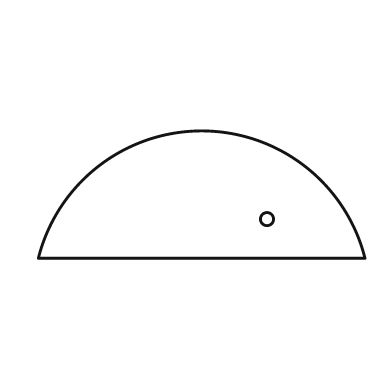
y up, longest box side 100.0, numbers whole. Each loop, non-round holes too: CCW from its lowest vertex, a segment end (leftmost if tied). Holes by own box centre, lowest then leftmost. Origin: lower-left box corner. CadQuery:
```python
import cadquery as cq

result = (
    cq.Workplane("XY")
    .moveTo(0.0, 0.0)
    .lineTo(100.0, 0.0)
    .threePointArc((50.0, 39.0), (0.0, 0.0))
    .close()
    .moveTo(70.0, 12.0)
    .circle(2.0)
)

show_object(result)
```